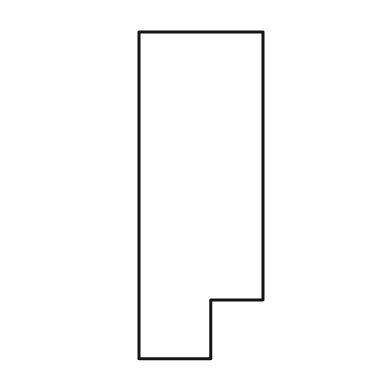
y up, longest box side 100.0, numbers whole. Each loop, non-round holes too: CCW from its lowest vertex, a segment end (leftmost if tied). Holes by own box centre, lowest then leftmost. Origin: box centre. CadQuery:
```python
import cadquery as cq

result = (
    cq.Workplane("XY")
    .moveTo(-19.0, -50.0)
    .lineTo(3.0, -50.0)
    .lineTo(3.0, -32.0)
    .lineTo(19.0, -32.0)
    .lineTo(19.0, 50.0)
    .lineTo(-19.0, 50.0)
    .close()
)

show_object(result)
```